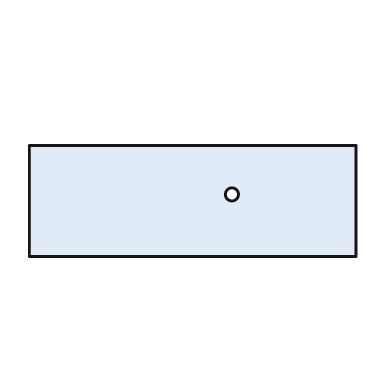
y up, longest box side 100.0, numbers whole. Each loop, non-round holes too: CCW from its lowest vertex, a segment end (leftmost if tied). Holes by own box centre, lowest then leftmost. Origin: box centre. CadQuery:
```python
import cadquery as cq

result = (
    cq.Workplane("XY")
    .moveTo(-50.0, -17.0)
    .lineTo(50.0, -17.0)
    .lineTo(50.0, 17.0)
    .lineTo(-50.0, 17.0)
    .close()
    .moveTo(12.0, 2.0)
    .circle(2.0)
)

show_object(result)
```